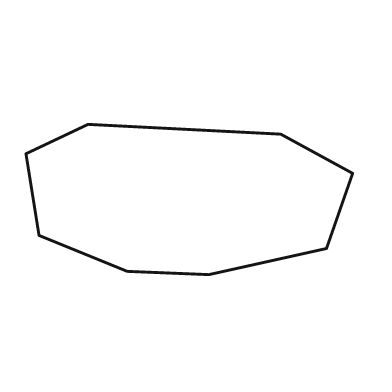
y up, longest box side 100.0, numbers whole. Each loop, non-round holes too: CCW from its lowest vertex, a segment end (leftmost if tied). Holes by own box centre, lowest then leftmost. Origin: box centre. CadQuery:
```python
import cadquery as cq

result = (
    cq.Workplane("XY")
    .moveTo(6.0, -23.0)
    .lineTo(42.0, -15.0)
    .lineTo(50.0, 8.0)
    .lineTo(28.0, 20.0)
    .lineTo(-31.0, 23.0)
    .lineTo(-50.0, 14.0)
    .lineTo(-46.0, -11.0)
    .lineTo(-19.0, -22.0)
    .close()
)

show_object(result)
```